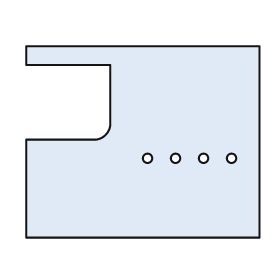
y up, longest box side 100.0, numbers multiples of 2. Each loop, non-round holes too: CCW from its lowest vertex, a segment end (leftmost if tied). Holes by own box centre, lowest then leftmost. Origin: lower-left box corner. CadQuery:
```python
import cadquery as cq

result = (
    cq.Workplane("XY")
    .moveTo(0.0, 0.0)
    .lineTo(100.0, 0.0)
    .lineTo(100.0, 82.0)
    .lineTo(0.0, 82.0)
    .lineTo(0.0, 74.0)
    .lineTo(36.0, 74.0)
    .lineTo(36.0, 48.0)
    .threePointArc((34.0, 44.0), (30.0, 42.0))
    .lineTo(0.0, 42.0)
    .close()
    .moveTo(52.0, 34.0)
    .circle(2.0)
    .moveTo(64.0, 34.0)
    .circle(2.0)
    .moveTo(76.0, 34.0)
    .circle(2.0)
    .moveTo(88.0, 34.0)
    .circle(2.0)
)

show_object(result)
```